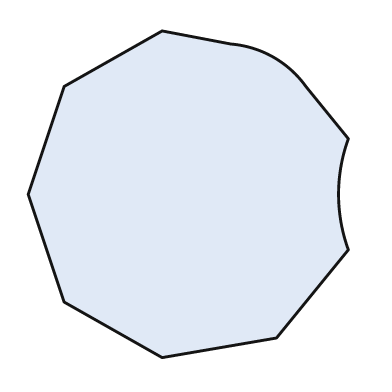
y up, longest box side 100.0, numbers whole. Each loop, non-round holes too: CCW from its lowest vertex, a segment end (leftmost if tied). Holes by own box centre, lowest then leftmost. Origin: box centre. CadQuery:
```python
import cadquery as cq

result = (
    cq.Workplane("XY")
    .moveTo(-8.0, -50.0)
    .lineTo(27.0, -44.0)
    .lineTo(49.0, -17.0)
    .threePointArc((46.0, 0.0), (49.0, 17.0))
    .lineTo(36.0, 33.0)
    .threePointArc((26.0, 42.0), (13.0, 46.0))
    .lineTo(-8.0, 50.0)
    .lineTo(-38.0, 33.0)
    .lineTo(-49.0, 0.0)
    .lineTo(-38.0, -33.0)
    .close()
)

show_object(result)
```